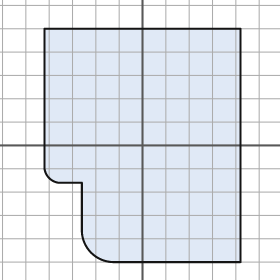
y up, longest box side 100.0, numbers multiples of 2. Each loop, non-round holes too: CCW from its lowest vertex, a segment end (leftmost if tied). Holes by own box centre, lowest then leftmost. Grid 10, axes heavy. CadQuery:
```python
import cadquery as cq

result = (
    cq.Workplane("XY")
    .moveTo(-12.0, -50.0)
    .lineTo(42.0, -50.0)
    .lineTo(42.0, 50.0)
    .lineTo(-42.0, 50.0)
    .lineTo(-42.0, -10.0)
    .threePointArc((-40.0, -14.0), (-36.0, -16.0))
    .lineTo(-26.0, -16.0)
    .lineTo(-26.0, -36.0)
    .threePointArc((-22.0, -46.0), (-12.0, -50.0))
    .close()
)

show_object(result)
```